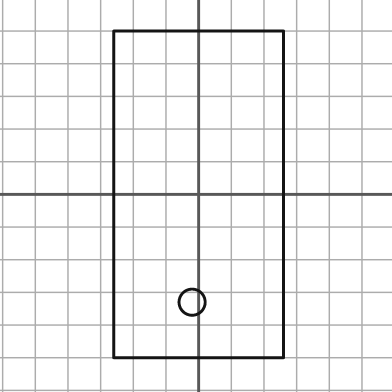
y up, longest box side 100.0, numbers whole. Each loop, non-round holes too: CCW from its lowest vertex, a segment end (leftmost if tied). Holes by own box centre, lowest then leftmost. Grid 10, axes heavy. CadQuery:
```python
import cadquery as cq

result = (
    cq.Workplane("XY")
    .moveTo(-26.0, -50.0)
    .lineTo(26.0, -50.0)
    .lineTo(26.0, 50.0)
    .lineTo(-26.0, 50.0)
    .close()
    .moveTo(-2.0, -33.0)
    .circle(4.0)
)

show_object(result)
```